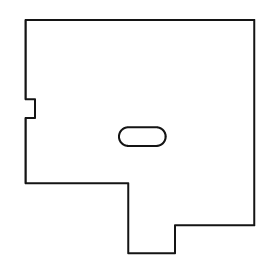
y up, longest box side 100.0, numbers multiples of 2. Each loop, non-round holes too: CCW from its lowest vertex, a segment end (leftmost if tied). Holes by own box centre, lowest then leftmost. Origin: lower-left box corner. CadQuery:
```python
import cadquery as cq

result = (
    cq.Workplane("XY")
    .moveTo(44.0, 0.0)
    .lineTo(64.0, 0.0)
    .lineTo(64.0, 12.0)
    .lineTo(98.0, 12.0)
    .lineTo(98.0, 100.0)
    .lineTo(0.0, 100.0)
    .lineTo(0.0, 66.0)
    .lineTo(4.0, 66.0)
    .lineTo(4.0, 58.0)
    .lineTo(0.0, 58.0)
    .lineTo(0.0, 30.0)
    .lineTo(44.0, 30.0)
    .close()
    .moveTo(44.0, 46.0)
    .lineTo(56.0, 46.0)
    .threePointArc((60.0, 50.0), (56.0, 54.0))
    .lineTo(44.0, 54.0)
    .threePointArc((40.0, 50.0), (44.0, 46.0))
    .close()
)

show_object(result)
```